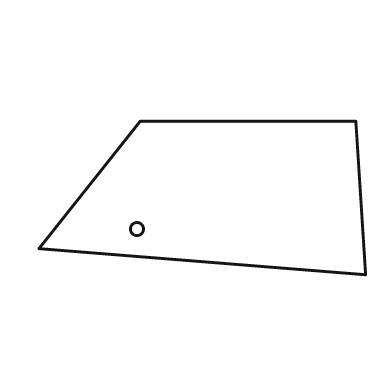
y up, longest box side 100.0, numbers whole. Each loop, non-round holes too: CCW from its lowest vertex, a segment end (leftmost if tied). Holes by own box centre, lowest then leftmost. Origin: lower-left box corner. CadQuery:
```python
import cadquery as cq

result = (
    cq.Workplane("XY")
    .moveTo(100.0, 0.0)
    .lineTo(97.0, 47.0)
    .lineTo(31.0, 47.0)
    .lineTo(0.0, 8.0)
    .close()
    .moveTo(30.0, 14.0)
    .circle(2.0)
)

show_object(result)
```